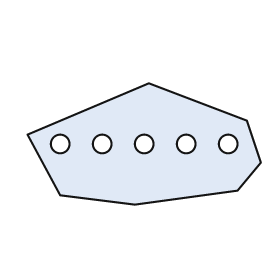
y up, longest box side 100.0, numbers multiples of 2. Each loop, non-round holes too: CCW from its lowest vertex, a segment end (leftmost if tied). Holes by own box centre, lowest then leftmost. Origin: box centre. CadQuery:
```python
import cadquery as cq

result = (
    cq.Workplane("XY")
    .moveTo(-4.0, -26.0)
    .lineTo(40.0, -20.0)
    .lineTo(50.0, -8.0)
    .lineTo(44.0, 10.0)
    .lineTo(2.0, 26.0)
    .lineTo(-50.0, 4.0)
    .lineTo(-36.0, -22.0)
    .close()
    .moveTo(-36.0, 0.0)
    .circle(4.0)
    .moveTo(-18.0, 0.0)
    .circle(4.0)
    .moveTo(0.0, 0.0)
    .circle(4.0)
    .moveTo(18.0, 0.0)
    .circle(4.0)
    .moveTo(36.0, 0.0)
    .circle(4.0)
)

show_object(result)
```